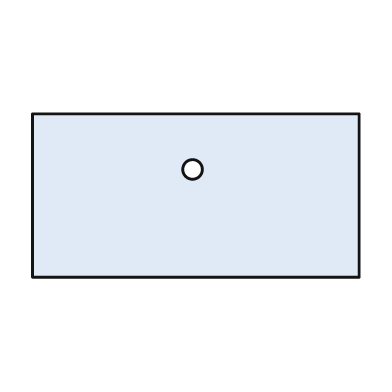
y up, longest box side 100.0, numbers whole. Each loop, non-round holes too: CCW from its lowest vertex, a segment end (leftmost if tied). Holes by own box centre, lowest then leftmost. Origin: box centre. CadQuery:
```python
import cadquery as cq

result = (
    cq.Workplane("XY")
    .moveTo(-50.0, -25.0)
    .lineTo(50.0, -25.0)
    .lineTo(50.0, 25.0)
    .lineTo(-50.0, 25.0)
    .close()
    .moveTo(-1.0, 8.0)
    .circle(3.0)
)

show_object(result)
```